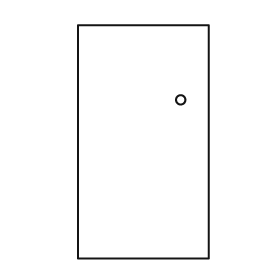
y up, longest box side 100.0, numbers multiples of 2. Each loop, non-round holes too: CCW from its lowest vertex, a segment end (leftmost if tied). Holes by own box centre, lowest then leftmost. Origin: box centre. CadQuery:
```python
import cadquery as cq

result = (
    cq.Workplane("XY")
    .moveTo(-28.0, -50.0)
    .lineTo(28.0, -50.0)
    .lineTo(28.0, 50.0)
    .lineTo(-28.0, 50.0)
    .close()
    .moveTo(16.0, 18.0)
    .circle(2.0)
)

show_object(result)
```